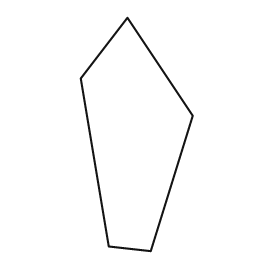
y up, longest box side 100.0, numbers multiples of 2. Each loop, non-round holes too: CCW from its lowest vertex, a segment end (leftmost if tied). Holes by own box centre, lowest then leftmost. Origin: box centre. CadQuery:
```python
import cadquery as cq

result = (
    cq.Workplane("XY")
    .moveTo(6.0, -50.0)
    .lineTo(24.0, 8.0)
    .lineTo(-4.0, 50.0)
    .lineTo(-24.0, 24.0)
    .lineTo(-12.0, -48.0)
    .close()
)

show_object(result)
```